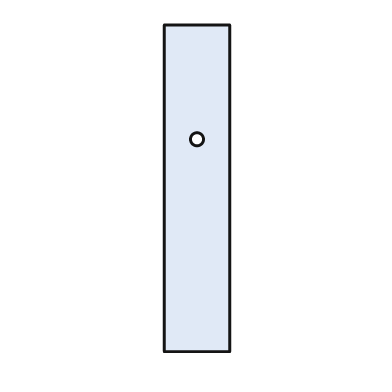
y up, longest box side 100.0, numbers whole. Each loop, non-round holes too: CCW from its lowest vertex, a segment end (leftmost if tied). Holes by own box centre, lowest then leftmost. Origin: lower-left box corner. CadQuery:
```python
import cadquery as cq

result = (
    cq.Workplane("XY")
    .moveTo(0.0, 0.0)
    .lineTo(20.0, 0.0)
    .lineTo(20.0, 100.0)
    .lineTo(0.0, 100.0)
    .close()
    .moveTo(10.0, 65.0)
    .circle(2.0)
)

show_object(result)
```